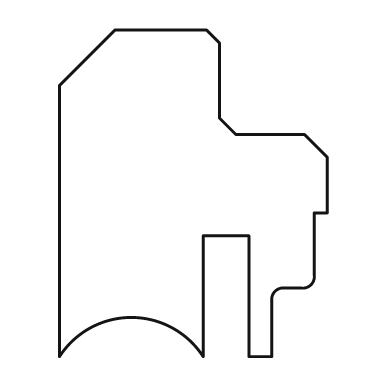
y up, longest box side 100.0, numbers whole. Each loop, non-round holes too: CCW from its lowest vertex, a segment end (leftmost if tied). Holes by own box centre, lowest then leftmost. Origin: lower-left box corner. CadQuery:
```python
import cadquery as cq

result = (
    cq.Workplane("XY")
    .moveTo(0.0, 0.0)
    .threePointArc((22.0, 12.0), (44.0, 0.0))
    .lineTo(44.0, 37.0)
    .lineTo(58.0, 37.0)
    .lineTo(58.0, 0.0)
    .lineTo(65.0, 0.0)
    .lineTo(65.0, 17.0)
    .threePointArc((66.0, 20.0), (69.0, 21.0))
    .lineTo(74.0, 21.0)
    .threePointArc((77.0, 22.0), (78.0, 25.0))
    .lineTo(78.0, 44.0)
    .lineTo(82.0, 44.0)
    .lineTo(82.0, 61.0)
    .lineTo(75.0, 68.0)
    .lineTo(54.0, 68.0)
    .lineTo(49.0, 73.0)
    .lineTo(49.0, 96.0)
    .lineTo(45.0, 100.0)
    .lineTo(17.0, 100.0)
    .lineTo(0.0, 83.0)
    .close()
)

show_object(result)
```